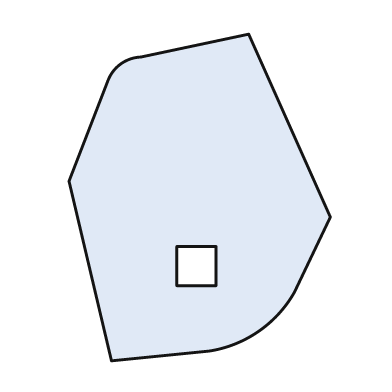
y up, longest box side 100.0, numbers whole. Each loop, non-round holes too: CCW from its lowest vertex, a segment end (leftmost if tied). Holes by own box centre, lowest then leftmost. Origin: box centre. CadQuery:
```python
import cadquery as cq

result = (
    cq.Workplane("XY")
    .moveTo(-27.0, -50.0)
    .lineTo(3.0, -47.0)
    .threePointArc((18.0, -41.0), (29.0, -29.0))
    .lineTo(40.0, -6.0)
    .lineTo(15.0, 50.0)
    .lineTo(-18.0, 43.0)
    .threePointArc((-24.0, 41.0), (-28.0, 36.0))
    .lineTo(-40.0, 5.0)
    .close()
    .moveTo(-7.0, -27.0)
    .lineTo(5.0, -27.0)
    .lineTo(5.0, -15.0)
    .lineTo(-7.0, -15.0)
    .close()
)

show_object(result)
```